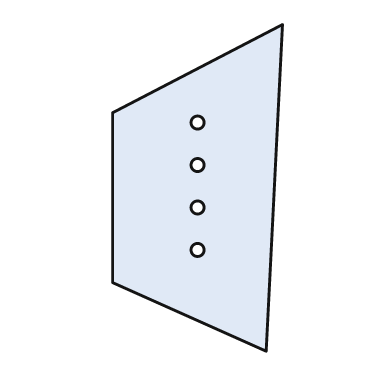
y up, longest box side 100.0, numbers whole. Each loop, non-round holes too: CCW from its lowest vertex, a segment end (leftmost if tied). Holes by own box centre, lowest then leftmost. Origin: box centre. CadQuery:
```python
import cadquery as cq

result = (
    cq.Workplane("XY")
    .moveTo(21.0, -50.0)
    .lineTo(26.0, 50.0)
    .lineTo(-26.0, 23.0)
    .lineTo(-26.0, -29.0)
    .close()
    .moveTo(0.0, -19.0)
    .circle(2.0)
    .moveTo(0.0, -6.0)
    .circle(2.0)
    .moveTo(0.0, 7.0)
    .circle(2.0)
    .moveTo(0.0, 20.0)
    .circle(2.0)
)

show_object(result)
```